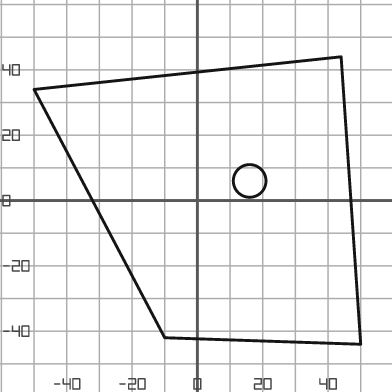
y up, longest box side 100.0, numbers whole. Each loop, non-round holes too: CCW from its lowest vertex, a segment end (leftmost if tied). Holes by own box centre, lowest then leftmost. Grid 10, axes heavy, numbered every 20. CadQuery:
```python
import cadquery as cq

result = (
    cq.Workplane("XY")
    .moveTo(50.0, -44.0)
    .lineTo(44.0, 44.0)
    .lineTo(-50.0, 34.0)
    .lineTo(-10.0, -42.0)
    .close()
    .moveTo(16.0, 6.0)
    .circle(5.0)
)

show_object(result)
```